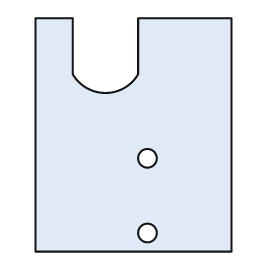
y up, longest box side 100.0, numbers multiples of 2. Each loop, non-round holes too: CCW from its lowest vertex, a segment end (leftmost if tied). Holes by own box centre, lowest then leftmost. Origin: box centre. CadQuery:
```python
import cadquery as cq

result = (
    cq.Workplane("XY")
    .moveTo(-42.0, -50.0)
    .lineTo(42.0, -50.0)
    .lineTo(42.0, 50.0)
    .lineTo(2.0, 50.0)
    .lineTo(2.0, 26.0)
    .threePointArc((-12.0, 18.0), (-26.0, 26.0))
    .lineTo(-26.0, 50.0)
    .lineTo(-42.0, 50.0)
    .close()
    .moveTo(6.0, -42.0)
    .circle(4.0)
    .moveTo(6.0, -10.0)
    .circle(4.0)
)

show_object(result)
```